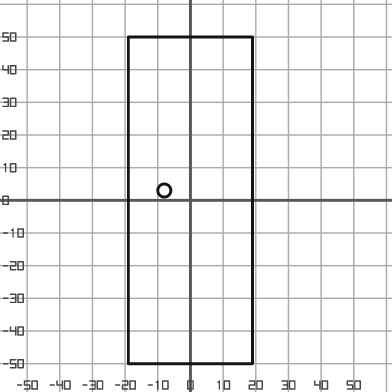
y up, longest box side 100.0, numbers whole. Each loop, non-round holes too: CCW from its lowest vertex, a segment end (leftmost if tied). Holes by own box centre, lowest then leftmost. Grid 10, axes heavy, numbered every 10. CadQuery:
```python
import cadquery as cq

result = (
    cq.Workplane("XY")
    .moveTo(-19.0, -50.0)
    .lineTo(19.0, -50.0)
    .lineTo(19.0, 50.0)
    .lineTo(-19.0, 50.0)
    .close()
    .moveTo(-8.0, 3.0)
    .circle(2.0)
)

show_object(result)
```